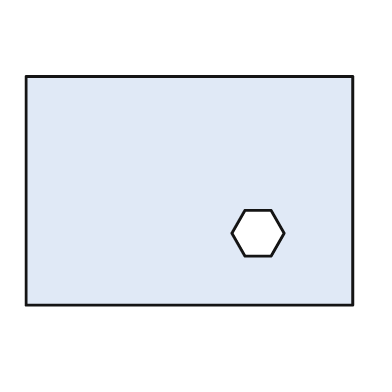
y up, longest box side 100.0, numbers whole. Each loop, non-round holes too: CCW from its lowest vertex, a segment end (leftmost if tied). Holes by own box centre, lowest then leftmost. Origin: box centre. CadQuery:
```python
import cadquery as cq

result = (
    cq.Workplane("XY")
    .moveTo(-50.0, -35.0)
    .lineTo(50.0, -35.0)
    .lineTo(50.0, 35.0)
    .lineTo(-50.0, 35.0)
    .close()
    .moveTo(17.0, -20.0)
    .lineTo(25.0, -20.0)
    .lineTo(29.0, -13.0)
    .lineTo(25.0, -6.0)
    .lineTo(17.0, -6.0)
    .lineTo(13.0, -13.0)
    .close()
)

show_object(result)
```